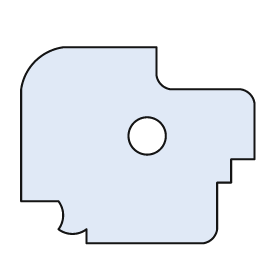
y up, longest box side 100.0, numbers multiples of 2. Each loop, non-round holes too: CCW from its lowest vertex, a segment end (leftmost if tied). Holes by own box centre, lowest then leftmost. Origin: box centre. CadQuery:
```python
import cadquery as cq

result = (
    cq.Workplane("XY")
    .moveTo(-22.0, -42.0)
    .lineTo(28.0, -42.0)
    .threePointArc((32.0, -40.0), (34.0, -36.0))
    .lineTo(34.0, -16.0)
    .lineTo(40.0, -16.0)
    .lineTo(40.0, -6.0)
    .lineTo(50.0, -6.0)
    .lineTo(50.0, 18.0)
    .threePointArc((48.0, 22.0), (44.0, 24.0))
    .lineTo(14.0, 24.0)
    .threePointArc((10.0, 26.0), (8.0, 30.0))
    .lineTo(8.0, 42.0)
    .lineTo(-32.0, 42.0)
    .threePointArc((-44.0, 36.0), (-50.0, 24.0))
    .lineTo(-50.0, -24.0)
    .lineTo(-34.0, -24.0)
    .threePointArc((-32.0, -30.0), (-34.0, -36.0))
    .threePointArc((-28.0, -38.0), (-22.0, -36.0))
    .close()
    .moveTo(4.0, 4.0)
    .circle(8.0)
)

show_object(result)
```